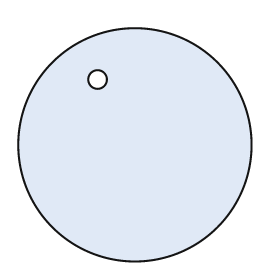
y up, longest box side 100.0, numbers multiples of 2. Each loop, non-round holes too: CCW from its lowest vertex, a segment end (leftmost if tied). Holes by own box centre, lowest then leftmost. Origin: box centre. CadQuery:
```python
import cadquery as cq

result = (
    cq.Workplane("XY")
    .moveTo(0.0, 0.0)
    .circle(50.0)
    .moveTo(-16.0, 28.0)
    .circle(4.0)
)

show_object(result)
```